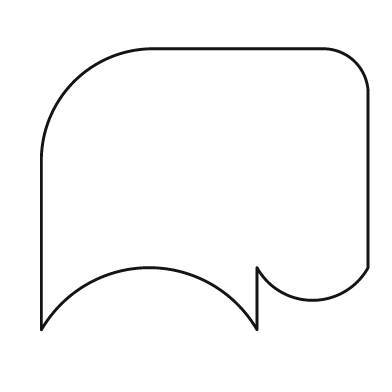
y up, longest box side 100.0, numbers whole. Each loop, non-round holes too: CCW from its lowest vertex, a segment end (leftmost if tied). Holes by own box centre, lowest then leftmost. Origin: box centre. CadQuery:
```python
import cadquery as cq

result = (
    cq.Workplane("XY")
    .moveTo(-50.0, -43.0)
    .threePointArc((-17.0, -24.0), (16.0, -43.0))
    .lineTo(16.0, -24.0)
    .threePointArc((33.0, -34.0), (50.0, -24.0))
    .lineTo(50.0, 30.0)
    .threePointArc((46.0, 39.0), (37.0, 43.0))
    .lineTo(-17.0, 43.0)
    .threePointArc((-40.0, 33.0), (-50.0, 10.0))
    .close()
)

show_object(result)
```